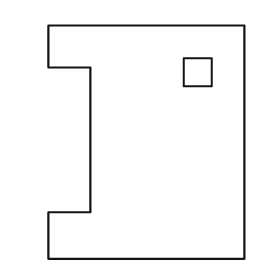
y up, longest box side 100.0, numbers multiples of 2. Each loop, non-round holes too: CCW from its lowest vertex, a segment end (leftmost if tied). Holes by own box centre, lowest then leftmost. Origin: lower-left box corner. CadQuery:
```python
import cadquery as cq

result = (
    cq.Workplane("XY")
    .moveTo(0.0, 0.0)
    .lineTo(84.0, 0.0)
    .lineTo(84.0, 100.0)
    .lineTo(0.0, 100.0)
    .lineTo(0.0, 82.0)
    .lineTo(18.0, 82.0)
    .lineTo(18.0, 20.0)
    .lineTo(0.0, 20.0)
    .close()
    .moveTo(58.0, 74.0)
    .lineTo(70.0, 74.0)
    .lineTo(70.0, 86.0)
    .lineTo(58.0, 86.0)
    .close()
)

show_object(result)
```